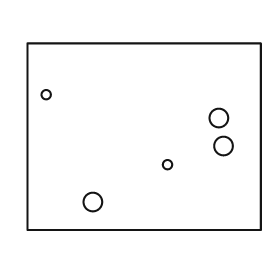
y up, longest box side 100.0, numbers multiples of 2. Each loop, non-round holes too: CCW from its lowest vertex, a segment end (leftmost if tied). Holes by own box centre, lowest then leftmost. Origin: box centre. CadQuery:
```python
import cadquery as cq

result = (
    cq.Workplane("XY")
    .moveTo(-50.0, -40.0)
    .lineTo(50.0, -40.0)
    .lineTo(50.0, 40.0)
    .lineTo(-50.0, 40.0)
    .close()
    .moveTo(-22.0, -28.0)
    .circle(4.0)
    .moveTo(10.0, -12.0)
    .circle(2.0)
    .moveTo(34.0, -4.0)
    .circle(4.0)
    .moveTo(32.0, 8.0)
    .circle(4.0)
    .moveTo(-42.0, 18.0)
    .circle(2.0)
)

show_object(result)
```